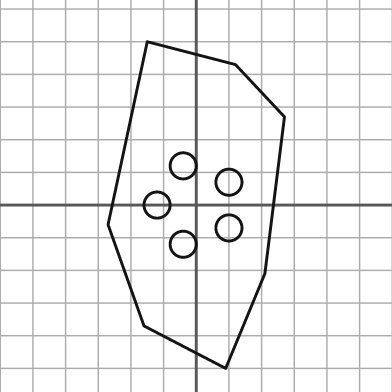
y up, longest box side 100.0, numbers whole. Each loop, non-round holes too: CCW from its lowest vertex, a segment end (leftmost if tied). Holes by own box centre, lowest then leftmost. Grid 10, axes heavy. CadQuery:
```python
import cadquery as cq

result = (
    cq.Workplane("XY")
    .moveTo(9.0, -50.0)
    .lineTo(21.0, -21.0)
    .lineTo(27.0, 27.0)
    .lineTo(12.0, 43.0)
    .lineTo(-15.0, 50.0)
    .lineTo(-27.0, -6.0)
    .lineTo(-16.0, -37.0)
    .close()
    .moveTo(-4.0, -12.0)
    .circle(4.0)
    .moveTo(10.0, -7.0)
    .circle(4.0)
    .moveTo(-12.0, 0.0)
    .circle(4.0)
    .moveTo(10.0, 7.0)
    .circle(4.0)
    .moveTo(-4.0, 12.0)
    .circle(4.0)
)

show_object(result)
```